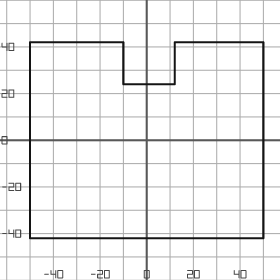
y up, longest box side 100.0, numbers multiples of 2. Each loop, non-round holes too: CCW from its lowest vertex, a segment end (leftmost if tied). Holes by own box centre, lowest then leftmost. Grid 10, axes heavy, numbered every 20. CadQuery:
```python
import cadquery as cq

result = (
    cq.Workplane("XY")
    .moveTo(-50.0, -42.0)
    .lineTo(50.0, -42.0)
    .lineTo(50.0, 42.0)
    .lineTo(12.0, 42.0)
    .lineTo(12.0, 24.0)
    .lineTo(-10.0, 24.0)
    .lineTo(-10.0, 42.0)
    .lineTo(-50.0, 42.0)
    .close()
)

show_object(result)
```